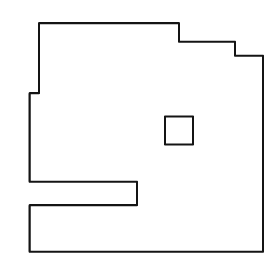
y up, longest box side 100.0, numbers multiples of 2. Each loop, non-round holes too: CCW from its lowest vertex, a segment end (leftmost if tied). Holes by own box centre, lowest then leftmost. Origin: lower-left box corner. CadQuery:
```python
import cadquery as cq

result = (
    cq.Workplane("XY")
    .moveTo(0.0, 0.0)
    .lineTo(100.0, 0.0)
    .lineTo(100.0, 84.0)
    .lineTo(88.0, 84.0)
    .lineTo(88.0, 90.0)
    .lineTo(64.0, 90.0)
    .lineTo(64.0, 98.0)
    .lineTo(4.0, 98.0)
    .lineTo(4.0, 68.0)
    .lineTo(0.0, 68.0)
    .lineTo(0.0, 30.0)
    .lineTo(46.0, 30.0)
    .lineTo(46.0, 20.0)
    .lineTo(0.0, 20.0)
    .close()
    .moveTo(58.0, 46.0)
    .lineTo(70.0, 46.0)
    .lineTo(70.0, 58.0)
    .lineTo(58.0, 58.0)
    .close()
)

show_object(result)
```